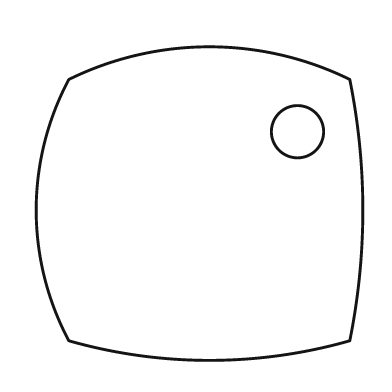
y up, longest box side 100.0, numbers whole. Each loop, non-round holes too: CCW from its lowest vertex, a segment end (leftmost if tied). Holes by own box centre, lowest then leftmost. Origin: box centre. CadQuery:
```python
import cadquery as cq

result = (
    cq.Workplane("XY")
    .moveTo(-40.0, -42.0)
    .threePointArc((3.0, -48.0), (46.0, -42.0))
    .threePointArc((50.0, -2.0), (46.0, 38.0))
    .threePointArc((3.0, 48.0), (-40.0, 38.0))
    .threePointArc((-50.0, -2.0), (-40.0, -42.0))
    .close()
    .moveTo(30.0, 22.0)
    .circle(8.0)
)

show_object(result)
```